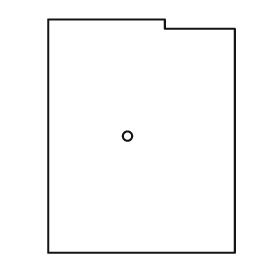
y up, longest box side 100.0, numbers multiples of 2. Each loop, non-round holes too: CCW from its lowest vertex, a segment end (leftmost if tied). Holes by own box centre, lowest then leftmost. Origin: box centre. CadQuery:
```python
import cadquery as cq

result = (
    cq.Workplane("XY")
    .moveTo(-40.0, -50.0)
    .lineTo(40.0, -50.0)
    .lineTo(40.0, 46.0)
    .lineTo(10.0, 46.0)
    .lineTo(10.0, 50.0)
    .lineTo(-40.0, 50.0)
    .close()
    .moveTo(-6.0, 0.0)
    .circle(2.0)
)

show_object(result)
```